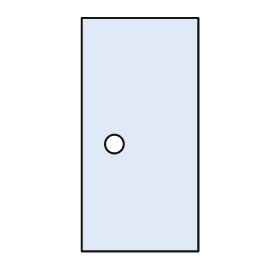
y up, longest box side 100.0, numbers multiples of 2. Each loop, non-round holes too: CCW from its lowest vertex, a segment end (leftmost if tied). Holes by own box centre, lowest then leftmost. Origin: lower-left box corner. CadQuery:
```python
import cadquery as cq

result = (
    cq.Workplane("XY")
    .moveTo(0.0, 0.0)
    .lineTo(50.0, 0.0)
    .lineTo(50.0, 100.0)
    .lineTo(0.0, 100.0)
    .close()
    .moveTo(14.0, 46.0)
    .circle(4.0)
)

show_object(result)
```